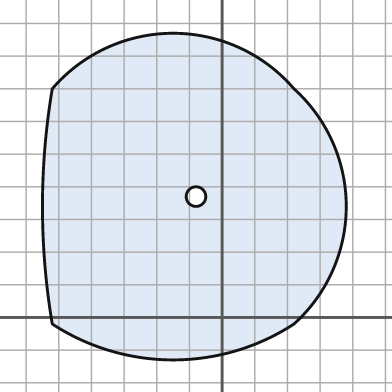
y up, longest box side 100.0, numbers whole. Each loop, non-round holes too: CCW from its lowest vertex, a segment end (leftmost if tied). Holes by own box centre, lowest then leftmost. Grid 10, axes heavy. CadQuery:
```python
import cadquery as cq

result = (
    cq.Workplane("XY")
    .moveTo(-52.0, -2.0)
    .threePointArc((-15.0, -13.0), (22.0, -2.0))
    .threePointArc((38.0, 34.0), (22.0, 70.0))
    .threePointArc((-15.0, 87.0), (-52.0, 70.0))
    .threePointArc((-55.0, 34.0), (-52.0, -2.0))
    .close()
    .moveTo(-8.0, 37.0)
    .circle(3.0)
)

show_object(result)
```